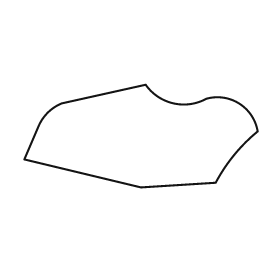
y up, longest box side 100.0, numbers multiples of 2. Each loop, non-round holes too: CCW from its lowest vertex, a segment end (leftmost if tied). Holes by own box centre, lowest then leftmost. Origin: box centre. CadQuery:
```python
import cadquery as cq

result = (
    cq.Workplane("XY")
    .moveTo(0.0, -22.0)
    .lineTo(32.0, -20.0)
    .threePointArc((40.0, -8.0), (50.0, 2.0))
    .threePointArc((42.0, 14.0), (28.0, 16.0))
    .threePointArc((14.0, 14.0), (2.0, 22.0))
    .lineTo(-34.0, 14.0)
    .threePointArc((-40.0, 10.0), (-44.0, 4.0))
    .lineTo(-50.0, -10.0)
    .close()
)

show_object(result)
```